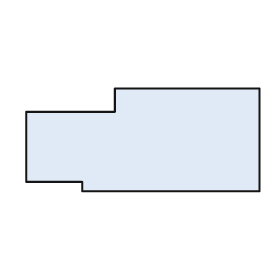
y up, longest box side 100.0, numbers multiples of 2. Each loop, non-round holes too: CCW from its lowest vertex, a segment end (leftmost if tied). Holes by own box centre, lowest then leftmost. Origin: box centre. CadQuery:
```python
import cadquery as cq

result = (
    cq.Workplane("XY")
    .moveTo(-26.0, -22.0)
    .lineTo(50.0, -22.0)
    .lineTo(50.0, 22.0)
    .lineTo(-12.0, 22.0)
    .lineTo(-12.0, 12.0)
    .lineTo(-50.0, 12.0)
    .lineTo(-50.0, -18.0)
    .lineTo(-26.0, -18.0)
    .close()
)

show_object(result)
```